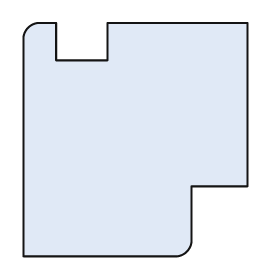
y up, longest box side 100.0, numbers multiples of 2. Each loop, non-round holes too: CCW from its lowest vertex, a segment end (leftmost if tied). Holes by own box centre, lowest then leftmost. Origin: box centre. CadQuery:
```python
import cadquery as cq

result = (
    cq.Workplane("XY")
    .moveTo(-48.0, -50.0)
    .lineTo(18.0, -50.0)
    .threePointArc((22.0, -48.0), (24.0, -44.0))
    .lineTo(24.0, -20.0)
    .lineTo(48.0, -20.0)
    .lineTo(48.0, 50.0)
    .lineTo(-12.0, 50.0)
    .lineTo(-12.0, 34.0)
    .lineTo(-34.0, 34.0)
    .lineTo(-34.0, 50.0)
    .lineTo(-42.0, 50.0)
    .threePointArc((-46.0, 48.0), (-48.0, 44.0))
    .close()
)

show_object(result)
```